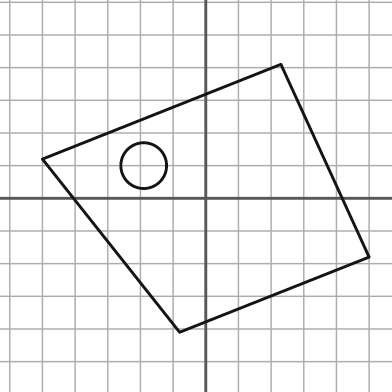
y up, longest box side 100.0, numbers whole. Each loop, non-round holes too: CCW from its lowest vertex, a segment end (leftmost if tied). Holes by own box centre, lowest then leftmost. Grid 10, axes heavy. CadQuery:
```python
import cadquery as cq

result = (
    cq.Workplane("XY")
    .moveTo(-8.0, -41.0)
    .lineTo(50.0, -18.0)
    .lineTo(23.0, 41.0)
    .lineTo(-50.0, 12.0)
    .close()
    .moveTo(-19.0, 10.0)
    .circle(7.0)
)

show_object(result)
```